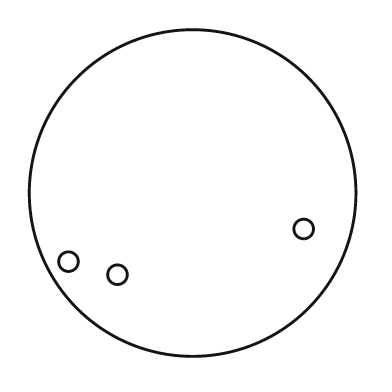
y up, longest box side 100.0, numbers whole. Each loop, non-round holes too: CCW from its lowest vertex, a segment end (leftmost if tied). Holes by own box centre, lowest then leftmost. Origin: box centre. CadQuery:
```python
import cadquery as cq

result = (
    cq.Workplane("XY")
    .moveTo(0.0, 0.0)
    .circle(50.0)
    .moveTo(-23.0, -25.0)
    .circle(3.0)
    .moveTo(-38.0, -21.0)
    .circle(3.0)
    .moveTo(34.0, -11.0)
    .circle(3.0)
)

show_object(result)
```